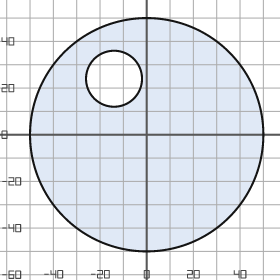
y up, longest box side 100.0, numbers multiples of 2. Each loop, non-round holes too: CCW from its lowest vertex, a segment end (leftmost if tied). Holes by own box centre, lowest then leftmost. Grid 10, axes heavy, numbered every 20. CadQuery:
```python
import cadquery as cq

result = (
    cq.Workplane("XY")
    .moveTo(0.0, 0.0)
    .circle(50.0)
    .moveTo(-14.0, 24.0)
    .circle(12.0)
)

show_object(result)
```